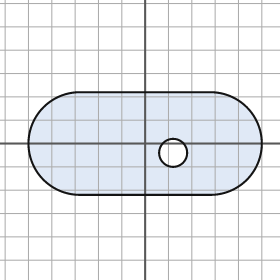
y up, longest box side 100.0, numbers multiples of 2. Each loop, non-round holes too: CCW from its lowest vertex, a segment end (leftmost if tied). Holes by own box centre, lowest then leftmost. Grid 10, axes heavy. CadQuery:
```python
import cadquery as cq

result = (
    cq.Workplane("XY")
    .moveTo(-28.0, -22.0)
    .lineTo(28.0, -22.0)
    .threePointArc((50.0, 0.0), (28.0, 22.0))
    .lineTo(-28.0, 22.0)
    .threePointArc((-50.0, 0.0), (-28.0, -22.0))
    .close()
    .moveTo(12.0, -4.0)
    .circle(6.0)
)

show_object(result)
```